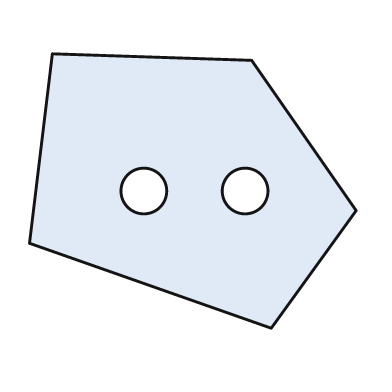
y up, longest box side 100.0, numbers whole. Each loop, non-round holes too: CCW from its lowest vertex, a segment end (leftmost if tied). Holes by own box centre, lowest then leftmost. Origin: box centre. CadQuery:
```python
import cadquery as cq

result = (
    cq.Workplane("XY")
    .moveTo(24.0, -42.0)
    .lineTo(50.0, -6.0)
    .lineTo(18.0, 40.0)
    .lineTo(-43.0, 42.0)
    .lineTo(-50.0, -16.0)
    .close()
    .moveTo(-15.0, 0.0)
    .circle(7.0)
    .moveTo(16.0, 0.0)
    .circle(7.0)
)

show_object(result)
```